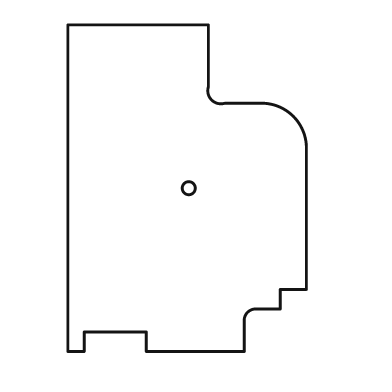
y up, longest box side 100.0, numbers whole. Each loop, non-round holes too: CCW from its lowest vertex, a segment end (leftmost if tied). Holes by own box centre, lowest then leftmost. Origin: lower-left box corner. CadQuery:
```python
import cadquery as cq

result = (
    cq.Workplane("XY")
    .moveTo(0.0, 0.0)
    .lineTo(5.0, 0.0)
    .lineTo(5.0, 6.0)
    .lineTo(24.0, 6.0)
    .lineTo(24.0, 0.0)
    .lineTo(54.0, 0.0)
    .lineTo(54.0, 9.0)
    .threePointArc((55.0, 12.0), (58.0, 13.0))
    .lineTo(65.0, 13.0)
    .lineTo(65.0, 19.0)
    .lineTo(73.0, 19.0)
    .lineTo(73.0, 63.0)
    .threePointArc((69.0, 72.0), (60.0, 76.0))
    .lineTo(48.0, 76.0)
    .threePointArc((44.0, 77.0), (43.0, 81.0))
    .lineTo(43.0, 100.0)
    .lineTo(0.0, 100.0)
    .close()
    .moveTo(37.0, 50.0)
    .circle(2.0)
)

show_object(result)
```